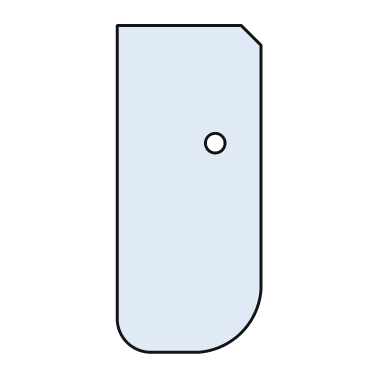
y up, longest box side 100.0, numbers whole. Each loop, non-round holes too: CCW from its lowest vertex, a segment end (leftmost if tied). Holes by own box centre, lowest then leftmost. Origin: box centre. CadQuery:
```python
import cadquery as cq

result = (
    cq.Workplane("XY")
    .moveTo(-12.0, -50.0)
    .lineTo(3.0, -50.0)
    .threePointArc((16.0, -44.0), (22.0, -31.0))
    .lineTo(22.0, 44.0)
    .lineTo(16.0, 50.0)
    .lineTo(-22.0, 50.0)
    .lineTo(-22.0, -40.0)
    .threePointArc((-19.0, -47.0), (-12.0, -50.0))
    .close()
    .moveTo(8.0, 14.0)
    .circle(3.0)
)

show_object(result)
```